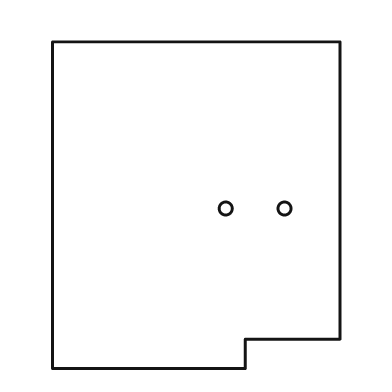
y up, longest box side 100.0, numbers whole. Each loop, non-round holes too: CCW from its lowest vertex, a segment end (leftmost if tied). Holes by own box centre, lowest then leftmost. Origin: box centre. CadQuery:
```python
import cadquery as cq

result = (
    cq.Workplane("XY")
    .moveTo(-44.0, -50.0)
    .lineTo(15.0, -50.0)
    .lineTo(15.0, -41.0)
    .lineTo(44.0, -41.0)
    .lineTo(44.0, 50.0)
    .lineTo(-44.0, 50.0)
    .close()
    .moveTo(9.0, -1.0)
    .circle(2.0)
    .moveTo(27.0, -1.0)
    .circle(2.0)
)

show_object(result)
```